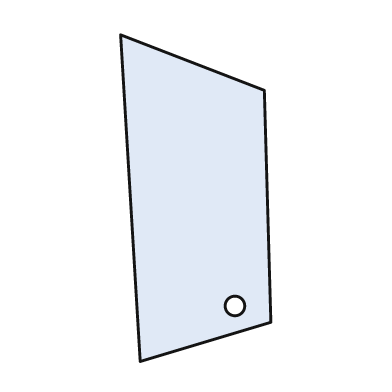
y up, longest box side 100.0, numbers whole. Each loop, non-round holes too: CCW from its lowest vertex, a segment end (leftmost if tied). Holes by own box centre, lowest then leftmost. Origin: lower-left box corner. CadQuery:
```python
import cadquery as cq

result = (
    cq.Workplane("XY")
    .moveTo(6.0, 0.0)
    .lineTo(46.0, 12.0)
    .lineTo(44.0, 83.0)
    .lineTo(0.0, 100.0)
    .close()
    .moveTo(35.0, 17.0)
    .circle(3.0)
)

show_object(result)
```